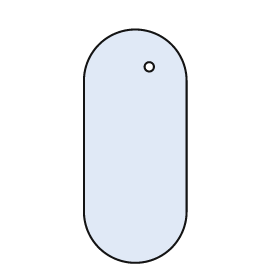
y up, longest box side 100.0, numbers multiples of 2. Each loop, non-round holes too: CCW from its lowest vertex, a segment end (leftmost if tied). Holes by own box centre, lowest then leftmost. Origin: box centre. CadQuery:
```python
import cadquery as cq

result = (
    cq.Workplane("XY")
    .moveTo(-22.0, -28.0)
    .threePointArc((0.0, -50.0), (22.0, -28.0))
    .lineTo(22.0, 28.0)
    .threePointArc((0.0, 50.0), (-22.0, 28.0))
    .close()
    .moveTo(6.0, 34.0)
    .circle(2.0)
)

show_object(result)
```